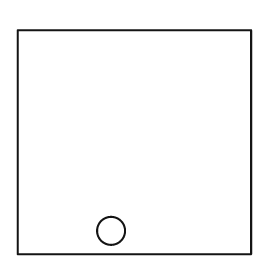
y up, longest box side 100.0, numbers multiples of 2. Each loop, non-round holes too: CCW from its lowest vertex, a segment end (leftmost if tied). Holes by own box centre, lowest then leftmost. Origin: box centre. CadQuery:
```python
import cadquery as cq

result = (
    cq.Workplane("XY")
    .moveTo(-50.0, -48.0)
    .lineTo(50.0, -48.0)
    .lineTo(50.0, 48.0)
    .lineTo(-50.0, 48.0)
    .close()
    .moveTo(-10.0, -38.0)
    .circle(6.0)
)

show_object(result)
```